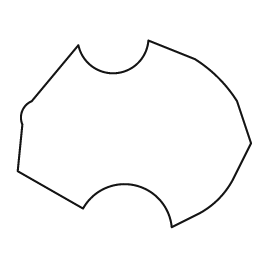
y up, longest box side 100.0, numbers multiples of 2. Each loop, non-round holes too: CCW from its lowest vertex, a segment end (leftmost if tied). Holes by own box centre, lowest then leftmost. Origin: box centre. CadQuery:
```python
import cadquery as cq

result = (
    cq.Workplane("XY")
    .moveTo(16.0, -40.0)
    .lineTo(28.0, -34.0)
    .threePointArc((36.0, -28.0), (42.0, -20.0))
    .lineTo(50.0, -4.0)
    .lineTo(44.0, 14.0)
    .threePointArc((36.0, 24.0), (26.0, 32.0))
    .lineTo(6.0, 40.0)
    .threePointArc((-8.0, 26.0), (-24.0, 38.0))
    .lineTo(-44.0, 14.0)
    .threePointArc((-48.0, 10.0), (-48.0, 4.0))
    .lineTo(-50.0, -16.0)
    .lineTo(-22.0, -32.0)
    .threePointArc((0.0, -22.0), (16.0, -40.0))
    .close()
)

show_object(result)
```